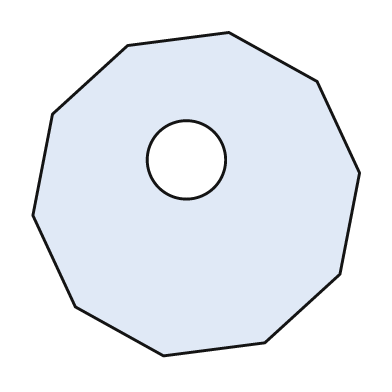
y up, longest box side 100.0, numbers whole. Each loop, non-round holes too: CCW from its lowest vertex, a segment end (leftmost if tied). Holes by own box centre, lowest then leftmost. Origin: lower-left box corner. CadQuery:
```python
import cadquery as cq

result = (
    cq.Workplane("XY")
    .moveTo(40.0, 0.0)
    .lineTo(71.0, 4.0)
    .lineTo(94.0, 25.0)
    .lineTo(100.0, 56.0)
    .lineTo(87.0, 84.0)
    .lineTo(60.0, 99.0)
    .lineTo(29.0, 95.0)
    .lineTo(6.0, 74.0)
    .lineTo(0.0, 43.0)
    .lineTo(13.0, 15.0)
    .close()
    .moveTo(47.0, 60.0)
    .circle(12.0)
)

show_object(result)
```